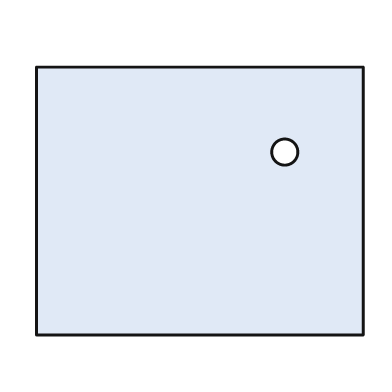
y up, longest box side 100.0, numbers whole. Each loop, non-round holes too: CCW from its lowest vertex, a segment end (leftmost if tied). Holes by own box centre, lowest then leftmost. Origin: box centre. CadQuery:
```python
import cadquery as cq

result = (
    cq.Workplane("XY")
    .moveTo(-50.0, -41.0)
    .lineTo(50.0, -41.0)
    .lineTo(50.0, 41.0)
    .lineTo(-50.0, 41.0)
    .close()
    .moveTo(26.0, 15.0)
    .circle(4.0)
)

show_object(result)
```